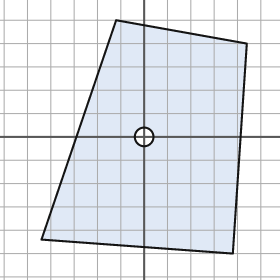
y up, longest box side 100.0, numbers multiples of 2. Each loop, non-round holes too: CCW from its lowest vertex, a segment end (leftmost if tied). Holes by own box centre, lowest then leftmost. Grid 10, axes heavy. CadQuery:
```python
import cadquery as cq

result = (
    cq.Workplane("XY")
    .moveTo(38.0, -50.0)
    .lineTo(44.0, 40.0)
    .lineTo(-12.0, 50.0)
    .lineTo(-44.0, -44.0)
    .close()
    .moveTo(0.0, 0.0)
    .circle(4.0)
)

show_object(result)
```